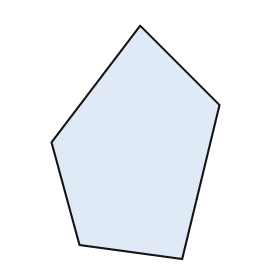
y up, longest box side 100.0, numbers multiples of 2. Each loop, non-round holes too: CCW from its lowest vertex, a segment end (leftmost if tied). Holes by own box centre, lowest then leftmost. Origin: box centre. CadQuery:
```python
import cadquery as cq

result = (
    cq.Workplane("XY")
    .moveTo(20.0, -50.0)
    .lineTo(36.0, 16.0)
    .lineTo(2.0, 50.0)
    .lineTo(-36.0, 0.0)
    .lineTo(-24.0, -44.0)
    .close()
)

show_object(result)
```